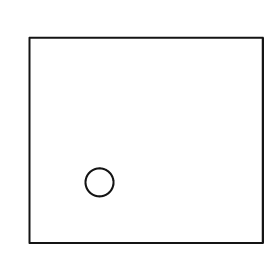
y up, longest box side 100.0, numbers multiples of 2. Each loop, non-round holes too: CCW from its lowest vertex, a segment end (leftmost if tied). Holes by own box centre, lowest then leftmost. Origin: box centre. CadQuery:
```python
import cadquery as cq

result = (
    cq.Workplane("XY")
    .moveTo(-50.0, -44.0)
    .lineTo(50.0, -44.0)
    .lineTo(50.0, 44.0)
    .lineTo(-50.0, 44.0)
    .close()
    .moveTo(-20.0, -18.0)
    .circle(6.0)
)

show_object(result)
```